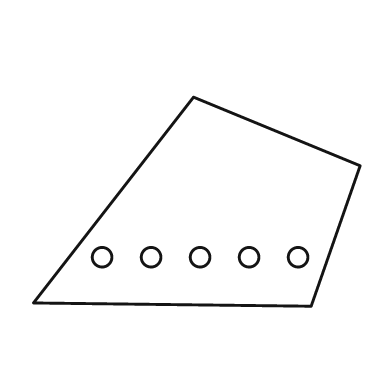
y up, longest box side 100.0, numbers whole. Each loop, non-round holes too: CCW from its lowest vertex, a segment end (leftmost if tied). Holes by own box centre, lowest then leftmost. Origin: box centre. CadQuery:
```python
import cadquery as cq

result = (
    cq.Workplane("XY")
    .moveTo(35.0, -32.0)
    .lineTo(50.0, 11.0)
    .lineTo(-1.0, 32.0)
    .lineTo(-50.0, -31.0)
    .close()
    .moveTo(-29.0, -17.0)
    .circle(3.0)
    .moveTo(-14.0, -17.0)
    .circle(3.0)
    .moveTo(1.0, -17.0)
    .circle(3.0)
    .moveTo(16.0, -17.0)
    .circle(3.0)
    .moveTo(31.0, -17.0)
    .circle(3.0)
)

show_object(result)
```